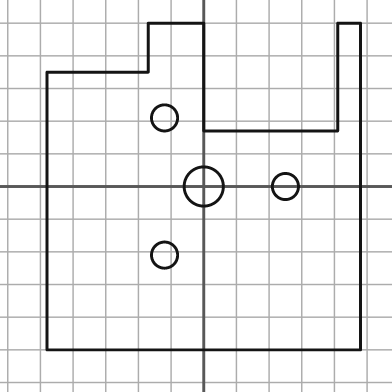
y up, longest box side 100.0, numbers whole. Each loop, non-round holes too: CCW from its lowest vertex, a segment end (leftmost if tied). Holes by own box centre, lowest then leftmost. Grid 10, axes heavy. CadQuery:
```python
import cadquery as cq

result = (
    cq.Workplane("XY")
    .moveTo(-48.0, -50.0)
    .lineTo(48.0, -50.0)
    .lineTo(48.0, 50.0)
    .lineTo(41.0, 50.0)
    .lineTo(41.0, 17.0)
    .lineTo(0.0, 17.0)
    .lineTo(0.0, 50.0)
    .lineTo(-17.0, 50.0)
    .lineTo(-17.0, 35.0)
    .lineTo(-48.0, 35.0)
    .close()
    .moveTo(-12.0, -21.0)
    .circle(4.0)
    .moveTo(0.0, 0.0)
    .circle(6.0)
    .moveTo(25.0, 0.0)
    .circle(4.0)
    .moveTo(-12.0, 21.0)
    .circle(4.0)
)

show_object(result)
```